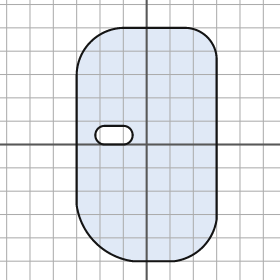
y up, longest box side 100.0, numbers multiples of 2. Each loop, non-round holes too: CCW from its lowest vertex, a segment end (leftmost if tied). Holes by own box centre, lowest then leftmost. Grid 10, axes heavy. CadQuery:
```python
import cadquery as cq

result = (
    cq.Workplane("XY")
    .moveTo(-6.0, -50.0)
    .lineTo(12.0, -50.0)
    .threePointArc((24.0, -44.0), (30.0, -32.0))
    .lineTo(30.0, 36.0)
    .threePointArc((26.0, 46.0), (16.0, 50.0))
    .lineTo(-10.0, 50.0)
    .threePointArc((-24.0, 44.0), (-30.0, 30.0))
    .lineTo(-30.0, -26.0)
    .threePointArc((-22.0, -42.0), (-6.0, -50.0))
    .close()
    .moveTo(-18.0, 0.0)
    .lineTo(-10.0, 0.0)
    .threePointArc((-6.0, 4.0), (-10.0, 8.0))
    .lineTo(-18.0, 8.0)
    .threePointArc((-22.0, 4.0), (-18.0, 0.0))
    .close()
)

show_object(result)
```